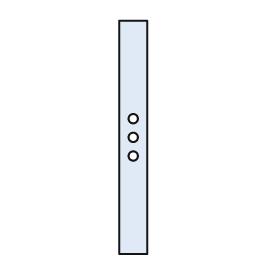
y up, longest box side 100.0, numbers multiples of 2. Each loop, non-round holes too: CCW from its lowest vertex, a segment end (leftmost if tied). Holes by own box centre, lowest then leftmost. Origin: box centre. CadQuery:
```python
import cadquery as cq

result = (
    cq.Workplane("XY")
    .moveTo(-6.0, -50.0)
    .lineTo(6.0, -50.0)
    .lineTo(6.0, 50.0)
    .lineTo(-6.0, 50.0)
    .close()
    .moveTo(0.0, -8.0)
    .circle(2.0)
    .moveTo(0.0, 0.0)
    .circle(2.0)
    .moveTo(0.0, 8.0)
    .circle(2.0)
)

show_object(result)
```